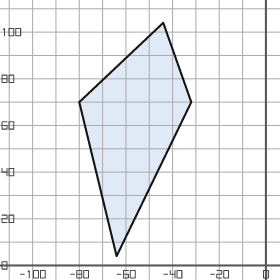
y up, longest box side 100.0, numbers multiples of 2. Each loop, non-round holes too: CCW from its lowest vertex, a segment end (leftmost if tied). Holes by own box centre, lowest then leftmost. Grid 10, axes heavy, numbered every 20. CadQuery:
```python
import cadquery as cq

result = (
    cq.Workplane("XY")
    .moveTo(-64.0, 4.0)
    .lineTo(-32.0, 70.0)
    .lineTo(-44.0, 104.0)
    .lineTo(-80.0, 70.0)
    .close()
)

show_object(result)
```